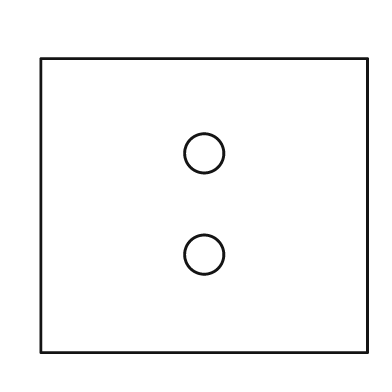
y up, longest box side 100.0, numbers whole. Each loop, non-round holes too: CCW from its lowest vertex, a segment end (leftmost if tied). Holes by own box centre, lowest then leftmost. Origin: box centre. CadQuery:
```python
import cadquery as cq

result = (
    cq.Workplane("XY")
    .moveTo(-50.0, -45.0)
    .lineTo(50.0, -45.0)
    .lineTo(50.0, 45.0)
    .lineTo(-50.0, 45.0)
    .close()
    .moveTo(0.0, -15.0)
    .circle(6.0)
    .moveTo(0.0, 16.0)
    .circle(6.0)
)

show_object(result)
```